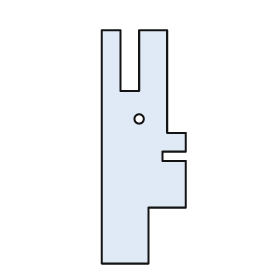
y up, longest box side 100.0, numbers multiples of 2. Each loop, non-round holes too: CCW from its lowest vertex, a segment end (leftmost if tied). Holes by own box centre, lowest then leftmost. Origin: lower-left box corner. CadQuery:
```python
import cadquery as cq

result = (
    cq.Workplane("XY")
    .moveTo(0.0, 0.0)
    .lineTo(20.0, 0.0)
    .lineTo(20.0, 24.0)
    .lineTo(36.0, 24.0)
    .lineTo(36.0, 44.0)
    .lineTo(26.0, 44.0)
    .lineTo(26.0, 48.0)
    .lineTo(36.0, 48.0)
    .lineTo(36.0, 56.0)
    .lineTo(28.0, 56.0)
    .lineTo(28.0, 100.0)
    .lineTo(16.0, 100.0)
    .lineTo(16.0, 74.0)
    .lineTo(8.0, 74.0)
    .lineTo(8.0, 100.0)
    .lineTo(0.0, 100.0)
    .close()
    .moveTo(16.0, 62.0)
    .circle(2.0)
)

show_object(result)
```